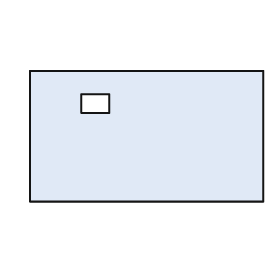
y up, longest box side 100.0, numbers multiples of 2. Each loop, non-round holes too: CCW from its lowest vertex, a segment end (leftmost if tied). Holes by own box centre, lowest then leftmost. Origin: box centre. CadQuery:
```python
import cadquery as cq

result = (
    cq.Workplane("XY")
    .moveTo(-50.0, -28.0)
    .lineTo(50.0, -28.0)
    .lineTo(50.0, 28.0)
    .lineTo(-50.0, 28.0)
    .close()
    .moveTo(-28.0, 10.0)
    .lineTo(-16.0, 10.0)
    .lineTo(-16.0, 18.0)
    .lineTo(-28.0, 18.0)
    .close()
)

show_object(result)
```